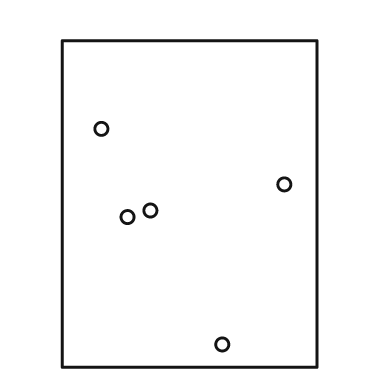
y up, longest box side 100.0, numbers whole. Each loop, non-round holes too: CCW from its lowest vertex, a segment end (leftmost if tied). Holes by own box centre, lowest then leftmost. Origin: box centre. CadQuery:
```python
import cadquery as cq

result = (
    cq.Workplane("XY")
    .moveTo(-39.0, -50.0)
    .lineTo(39.0, -50.0)
    .lineTo(39.0, 50.0)
    .lineTo(-39.0, 50.0)
    .close()
    .moveTo(10.0, -43.0)
    .circle(2.0)
    .moveTo(-19.0, -4.0)
    .circle(2.0)
    .moveTo(-12.0, -2.0)
    .circle(2.0)
    .moveTo(29.0, 6.0)
    .circle(2.0)
    .moveTo(-27.0, 23.0)
    .circle(2.0)
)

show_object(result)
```